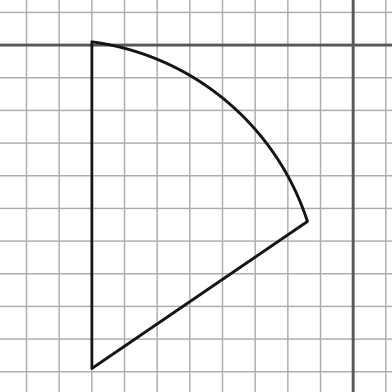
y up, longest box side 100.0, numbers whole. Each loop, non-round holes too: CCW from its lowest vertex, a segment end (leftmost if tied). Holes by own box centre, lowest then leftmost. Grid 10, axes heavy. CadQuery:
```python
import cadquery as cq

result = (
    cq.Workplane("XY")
    .moveTo(-80.0, -99.0)
    .lineTo(-14.0, -54.0)
    .threePointArc((-39.0, -17.0), (-80.0, 1.0))
    .close()
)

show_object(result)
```